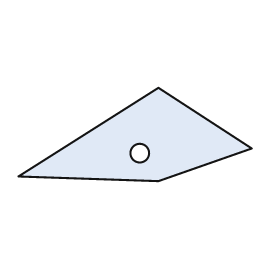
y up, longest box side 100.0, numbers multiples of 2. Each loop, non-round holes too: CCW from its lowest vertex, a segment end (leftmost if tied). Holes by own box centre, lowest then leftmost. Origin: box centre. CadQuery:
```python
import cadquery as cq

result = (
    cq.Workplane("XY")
    .moveTo(10.0, -20.0)
    .lineTo(50.0, -6.0)
    .lineTo(10.0, 20.0)
    .lineTo(-50.0, -18.0)
    .close()
    .moveTo(2.0, -8.0)
    .circle(4.0)
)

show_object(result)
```